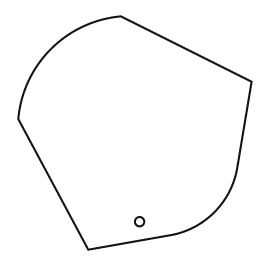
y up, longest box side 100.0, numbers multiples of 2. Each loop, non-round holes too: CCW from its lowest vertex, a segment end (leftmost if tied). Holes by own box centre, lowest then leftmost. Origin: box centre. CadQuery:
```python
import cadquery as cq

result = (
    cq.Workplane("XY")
    .moveTo(-20.0, -50.0)
    .lineTo(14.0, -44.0)
    .threePointArc((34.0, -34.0), (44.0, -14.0))
    .lineTo(50.0, 22.0)
    .lineTo(-6.0, 50.0)
    .threePointArc((-36.0, 36.0), (-50.0, 6.0))
    .close()
    .moveTo(2.0, -38.0)
    .circle(2.0)
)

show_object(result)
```